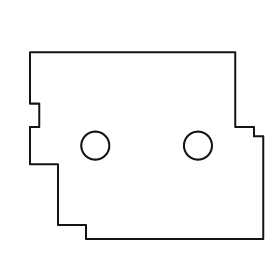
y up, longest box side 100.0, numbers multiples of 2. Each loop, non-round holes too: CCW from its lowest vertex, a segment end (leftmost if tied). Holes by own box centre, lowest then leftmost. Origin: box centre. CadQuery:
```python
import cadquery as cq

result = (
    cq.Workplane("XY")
    .moveTo(-26.0, -40.0)
    .lineTo(50.0, -40.0)
    .lineTo(50.0, 4.0)
    .lineTo(46.0, 4.0)
    .lineTo(46.0, 8.0)
    .lineTo(38.0, 8.0)
    .lineTo(38.0, 40.0)
    .lineTo(-50.0, 40.0)
    .lineTo(-50.0, 18.0)
    .lineTo(-46.0, 18.0)
    .lineTo(-46.0, 8.0)
    .lineTo(-50.0, 8.0)
    .lineTo(-50.0, -8.0)
    .lineTo(-38.0, -8.0)
    .lineTo(-38.0, -34.0)
    .lineTo(-26.0, -34.0)
    .close()
    .moveTo(-22.0, 0.0)
    .circle(6.0)
    .moveTo(22.0, 0.0)
    .circle(6.0)
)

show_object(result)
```